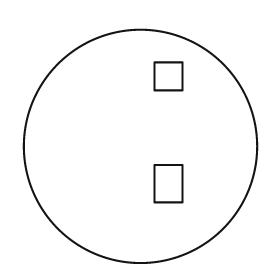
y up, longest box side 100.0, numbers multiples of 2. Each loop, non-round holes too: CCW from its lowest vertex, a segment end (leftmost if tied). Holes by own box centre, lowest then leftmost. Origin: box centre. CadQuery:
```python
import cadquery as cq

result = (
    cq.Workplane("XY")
    .moveTo(0.0, 0.0)
    .circle(50.0)
    .moveTo(6.0, -24.0)
    .lineTo(18.0, -24.0)
    .lineTo(18.0, -8.0)
    .lineTo(6.0, -8.0)
    .close()
    .moveTo(6.0, 24.0)
    .lineTo(18.0, 24.0)
    .lineTo(18.0, 36.0)
    .lineTo(6.0, 36.0)
    .close()
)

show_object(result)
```